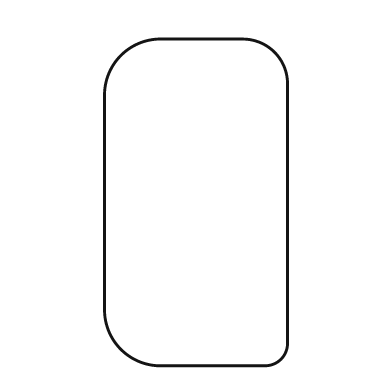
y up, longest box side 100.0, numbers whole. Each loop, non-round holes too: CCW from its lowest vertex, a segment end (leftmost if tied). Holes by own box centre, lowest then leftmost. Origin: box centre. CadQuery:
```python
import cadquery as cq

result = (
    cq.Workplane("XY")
    .moveTo(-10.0, -50.0)
    .lineTo(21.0, -50.0)
    .threePointArc((26.0, -48.0), (28.0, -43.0))
    .lineTo(28.0, 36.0)
    .threePointArc((24.0, 46.0), (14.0, 50.0))
    .lineTo(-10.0, 50.0)
    .threePointArc((-23.0, 45.0), (-28.0, 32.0))
    .lineTo(-28.0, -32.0)
    .threePointArc((-23.0, -45.0), (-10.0, -50.0))
    .close()
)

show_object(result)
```